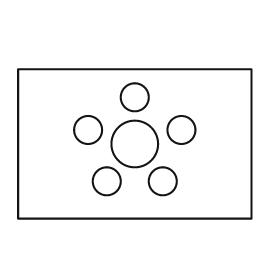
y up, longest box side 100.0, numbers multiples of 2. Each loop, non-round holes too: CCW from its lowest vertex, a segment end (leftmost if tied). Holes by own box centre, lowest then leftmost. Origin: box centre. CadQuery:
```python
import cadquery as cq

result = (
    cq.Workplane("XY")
    .moveTo(-50.0, -32.0)
    .lineTo(50.0, -32.0)
    .lineTo(50.0, 32.0)
    .lineTo(-50.0, 32.0)
    .close()
    .moveTo(-12.0, -16.0)
    .circle(6.0)
    .moveTo(12.0, -16.0)
    .circle(6.0)
    .moveTo(0.0, 0.0)
    .circle(10.0)
    .moveTo(-20.0, 6.0)
    .circle(6.0)
    .moveTo(20.0, 6.0)
    .circle(6.0)
    .moveTo(0.0, 20.0)
    .circle(6.0)
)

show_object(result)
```